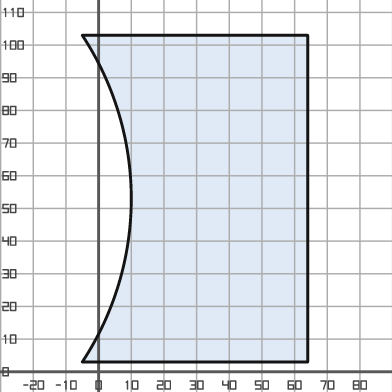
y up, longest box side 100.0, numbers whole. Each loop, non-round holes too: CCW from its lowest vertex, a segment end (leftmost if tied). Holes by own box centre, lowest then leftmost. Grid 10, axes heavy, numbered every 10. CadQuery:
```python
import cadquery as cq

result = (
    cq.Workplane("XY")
    .moveTo(-5.0, 3.0)
    .lineTo(64.0, 3.0)
    .lineTo(64.0, 103.0)
    .lineTo(-5.0, 103.0)
    .threePointArc((10.0, 53.0), (-5.0, 3.0))
    .close()
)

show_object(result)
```